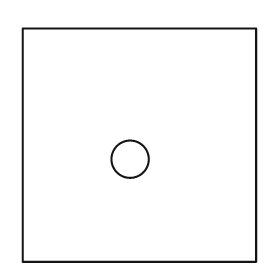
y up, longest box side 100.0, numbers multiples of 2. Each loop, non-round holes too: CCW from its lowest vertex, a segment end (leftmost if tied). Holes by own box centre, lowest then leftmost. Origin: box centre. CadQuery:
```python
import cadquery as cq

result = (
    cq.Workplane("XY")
    .moveTo(-50.0, -50.0)
    .lineTo(50.0, -50.0)
    .lineTo(50.0, 50.0)
    .lineTo(-50.0, 50.0)
    .close()
    .moveTo(-4.0, -6.0)
    .circle(8.0)
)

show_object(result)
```